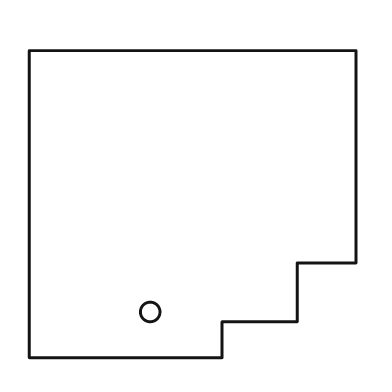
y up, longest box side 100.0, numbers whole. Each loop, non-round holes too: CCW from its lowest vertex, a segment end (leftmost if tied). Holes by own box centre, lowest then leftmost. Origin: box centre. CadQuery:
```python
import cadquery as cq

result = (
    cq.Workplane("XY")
    .moveTo(-50.0, -47.0)
    .lineTo(9.0, -47.0)
    .lineTo(9.0, -36.0)
    .lineTo(32.0, -36.0)
    .lineTo(32.0, -18.0)
    .lineTo(50.0, -18.0)
    .lineTo(50.0, 47.0)
    .lineTo(-50.0, 47.0)
    .close()
    .moveTo(-13.0, -33.0)
    .circle(3.0)
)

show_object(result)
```